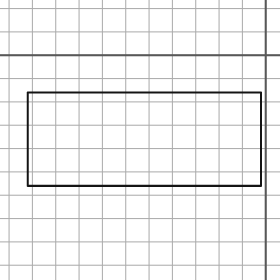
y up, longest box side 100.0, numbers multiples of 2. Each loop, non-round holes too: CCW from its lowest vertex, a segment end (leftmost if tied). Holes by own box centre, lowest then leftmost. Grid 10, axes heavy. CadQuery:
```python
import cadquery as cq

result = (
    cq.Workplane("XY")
    .moveTo(-102.0, -56.0)
    .lineTo(-2.0, -56.0)
    .lineTo(-2.0, -16.0)
    .lineTo(-102.0, -16.0)
    .close()
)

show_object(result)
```